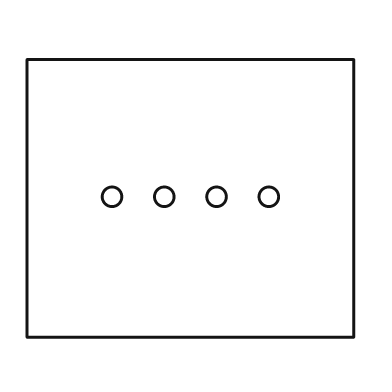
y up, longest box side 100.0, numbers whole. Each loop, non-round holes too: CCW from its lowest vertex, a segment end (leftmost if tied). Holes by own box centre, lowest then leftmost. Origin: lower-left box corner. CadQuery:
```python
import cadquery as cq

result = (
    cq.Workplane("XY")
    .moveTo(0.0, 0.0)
    .lineTo(100.0, 0.0)
    .lineTo(100.0, 85.0)
    .lineTo(0.0, 85.0)
    .close()
    .moveTo(26.0, 43.0)
    .circle(3.0)
    .moveTo(42.0, 43.0)
    .circle(3.0)
    .moveTo(58.0, 43.0)
    .circle(3.0)
    .moveTo(74.0, 43.0)
    .circle(3.0)
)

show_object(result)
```